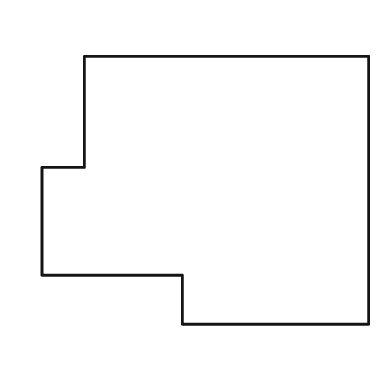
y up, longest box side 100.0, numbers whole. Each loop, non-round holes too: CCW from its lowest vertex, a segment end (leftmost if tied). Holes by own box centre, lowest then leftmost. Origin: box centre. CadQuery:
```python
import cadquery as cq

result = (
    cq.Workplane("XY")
    .moveTo(-7.0, -41.0)
    .lineTo(50.0, -41.0)
    .lineTo(50.0, 41.0)
    .lineTo(-37.0, 41.0)
    .lineTo(-37.0, 7.0)
    .lineTo(-50.0, 7.0)
    .lineTo(-50.0, -26.0)
    .lineTo(-7.0, -26.0)
    .close()
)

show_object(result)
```